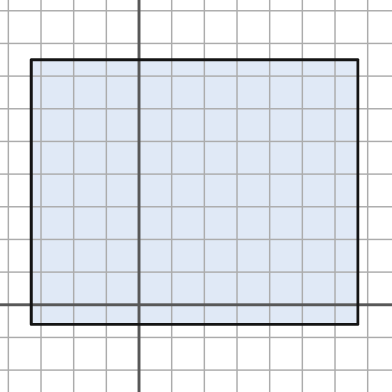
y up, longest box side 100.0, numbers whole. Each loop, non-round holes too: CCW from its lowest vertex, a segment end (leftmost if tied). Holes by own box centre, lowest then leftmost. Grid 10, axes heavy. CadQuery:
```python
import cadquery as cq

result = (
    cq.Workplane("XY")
    .moveTo(-33.0, -6.0)
    .lineTo(67.0, -6.0)
    .lineTo(67.0, 75.0)
    .lineTo(-33.0, 75.0)
    .close()
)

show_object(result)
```